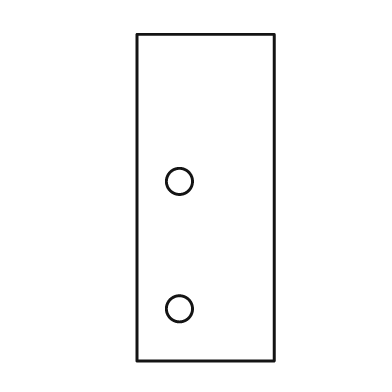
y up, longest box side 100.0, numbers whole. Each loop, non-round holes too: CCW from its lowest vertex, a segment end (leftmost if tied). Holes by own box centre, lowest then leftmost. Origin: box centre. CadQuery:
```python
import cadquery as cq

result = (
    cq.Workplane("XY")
    .moveTo(-21.0, -50.0)
    .lineTo(21.0, -50.0)
    .lineTo(21.0, 50.0)
    .lineTo(-21.0, 50.0)
    .close()
    .moveTo(-8.0, -34.0)
    .circle(4.0)
    .moveTo(-8.0, 5.0)
    .circle(4.0)
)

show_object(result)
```